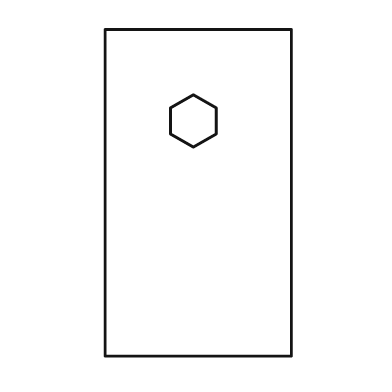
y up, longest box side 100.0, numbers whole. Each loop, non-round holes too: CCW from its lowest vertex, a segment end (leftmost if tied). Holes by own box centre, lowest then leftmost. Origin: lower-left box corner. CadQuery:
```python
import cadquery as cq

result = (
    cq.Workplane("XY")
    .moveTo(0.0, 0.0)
    .lineTo(57.0, 0.0)
    .lineTo(57.0, 100.0)
    .lineTo(0.0, 100.0)
    .close()
    .moveTo(27.0, 64.0)
    .lineTo(34.0, 68.0)
    .lineTo(34.0, 76.0)
    .lineTo(27.0, 80.0)
    .lineTo(20.0, 76.0)
    .lineTo(20.0, 68.0)
    .close()
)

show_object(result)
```